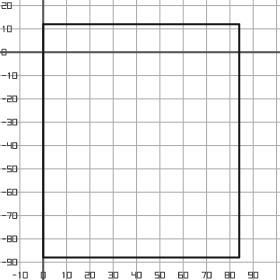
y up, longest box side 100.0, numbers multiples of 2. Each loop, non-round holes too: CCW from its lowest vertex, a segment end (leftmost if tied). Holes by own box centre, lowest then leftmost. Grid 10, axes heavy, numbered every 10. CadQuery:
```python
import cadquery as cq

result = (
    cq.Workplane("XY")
    .moveTo(0.0, -88.0)
    .lineTo(84.0, -88.0)
    .lineTo(84.0, 12.0)
    .lineTo(0.0, 12.0)
    .close()
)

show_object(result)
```